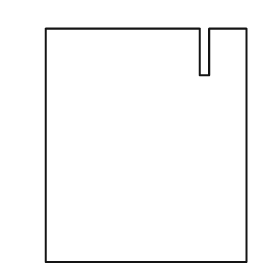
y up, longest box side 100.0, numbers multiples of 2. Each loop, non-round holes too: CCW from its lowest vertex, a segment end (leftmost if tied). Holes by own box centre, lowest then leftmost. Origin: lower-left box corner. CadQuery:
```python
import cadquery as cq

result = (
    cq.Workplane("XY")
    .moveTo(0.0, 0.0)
    .lineTo(86.0, 0.0)
    .lineTo(86.0, 100.0)
    .lineTo(70.0, 100.0)
    .lineTo(70.0, 80.0)
    .lineTo(66.0, 80.0)
    .lineTo(66.0, 100.0)
    .lineTo(0.0, 100.0)
    .close()
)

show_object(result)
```